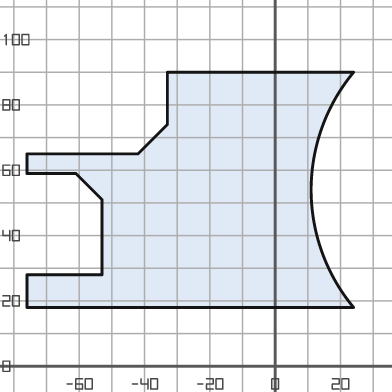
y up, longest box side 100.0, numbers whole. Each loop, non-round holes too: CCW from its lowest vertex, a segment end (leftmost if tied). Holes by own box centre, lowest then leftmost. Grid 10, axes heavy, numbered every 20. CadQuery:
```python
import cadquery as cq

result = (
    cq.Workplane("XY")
    .moveTo(-76.0, 18.0)
    .lineTo(24.0, 18.0)
    .threePointArc((11.0, 54.0), (24.0, 90.0))
    .lineTo(-33.0, 90.0)
    .lineTo(-33.0, 74.0)
    .lineTo(-42.0, 65.0)
    .lineTo(-76.0, 65.0)
    .lineTo(-76.0, 59.0)
    .lineTo(-61.0, 59.0)
    .lineTo(-53.0, 51.0)
    .lineTo(-53.0, 28.0)
    .lineTo(-76.0, 28.0)
    .close()
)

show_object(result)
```